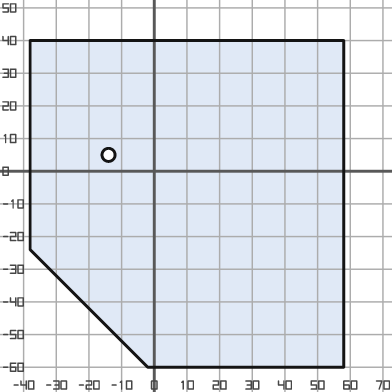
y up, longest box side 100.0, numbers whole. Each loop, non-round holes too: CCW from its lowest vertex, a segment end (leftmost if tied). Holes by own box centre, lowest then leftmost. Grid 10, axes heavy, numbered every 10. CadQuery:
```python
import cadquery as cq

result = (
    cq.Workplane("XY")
    .moveTo(-2.0, -60.0)
    .lineTo(58.0, -60.0)
    .lineTo(58.0, 40.0)
    .lineTo(-38.0, 40.0)
    .lineTo(-38.0, -24.0)
    .close()
    .moveTo(-14.0, 5.0)
    .circle(2.0)
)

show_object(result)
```